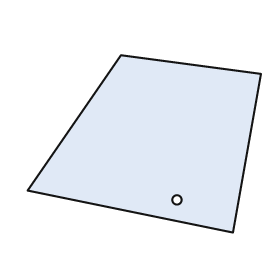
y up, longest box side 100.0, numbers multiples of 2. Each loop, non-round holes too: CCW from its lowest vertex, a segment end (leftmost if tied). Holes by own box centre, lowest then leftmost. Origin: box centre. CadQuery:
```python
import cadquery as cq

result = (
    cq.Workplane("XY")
    .moveTo(38.0, -38.0)
    .lineTo(50.0, 30.0)
    .lineTo(-10.0, 38.0)
    .lineTo(-50.0, -20.0)
    .close()
    .moveTo(14.0, -24.0)
    .circle(2.0)
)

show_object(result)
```